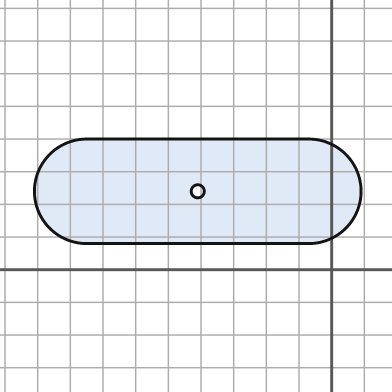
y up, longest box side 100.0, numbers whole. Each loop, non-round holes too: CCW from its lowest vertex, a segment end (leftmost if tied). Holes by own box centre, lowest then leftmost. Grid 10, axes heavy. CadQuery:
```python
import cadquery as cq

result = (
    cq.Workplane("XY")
    .moveTo(-75.0, 8.0)
    .lineTo(-7.0, 8.0)
    .threePointArc((9.0, 24.0), (-7.0, 40.0))
    .lineTo(-75.0, 40.0)
    .threePointArc((-91.0, 24.0), (-75.0, 8.0))
    .close()
    .moveTo(-41.0, 24.0)
    .circle(2.0)
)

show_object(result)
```